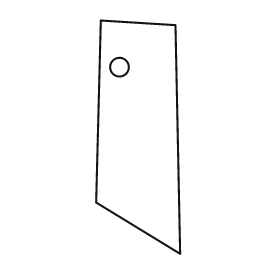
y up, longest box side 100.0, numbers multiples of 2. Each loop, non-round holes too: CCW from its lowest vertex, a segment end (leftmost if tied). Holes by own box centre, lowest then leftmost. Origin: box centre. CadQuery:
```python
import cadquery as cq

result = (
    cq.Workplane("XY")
    .moveTo(18.0, -50.0)
    .lineTo(16.0, 48.0)
    .lineTo(-16.0, 50.0)
    .lineTo(-18.0, -28.0)
    .close()
    .moveTo(-8.0, 30.0)
    .circle(4.0)
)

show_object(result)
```